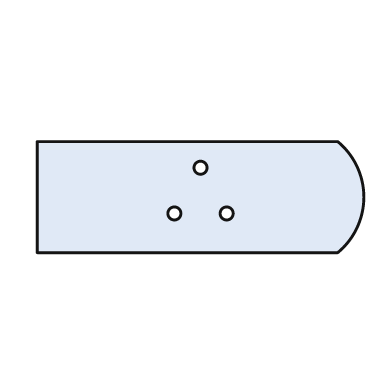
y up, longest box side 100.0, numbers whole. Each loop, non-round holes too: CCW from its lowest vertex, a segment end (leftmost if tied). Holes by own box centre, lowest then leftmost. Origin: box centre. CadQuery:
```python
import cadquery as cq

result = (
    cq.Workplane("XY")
    .moveTo(-50.0, -17.0)
    .lineTo(42.0, -17.0)
    .threePointArc((50.0, 0.0), (42.0, 17.0))
    .lineTo(-50.0, 17.0)
    .close()
    .moveTo(-8.0, -5.0)
    .circle(2.0)
    .moveTo(8.0, -5.0)
    .circle(2.0)
    .moveTo(0.0, 9.0)
    .circle(2.0)
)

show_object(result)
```